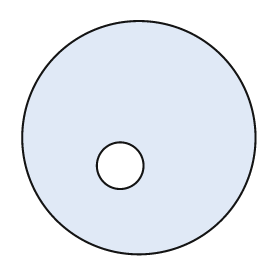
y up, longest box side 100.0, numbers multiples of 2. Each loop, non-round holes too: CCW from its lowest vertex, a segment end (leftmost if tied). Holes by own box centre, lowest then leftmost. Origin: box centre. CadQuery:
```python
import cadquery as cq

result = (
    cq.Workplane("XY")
    .moveTo(0.0, 0.0)
    .circle(50.0)
    .moveTo(-8.0, -12.0)
    .circle(10.0)
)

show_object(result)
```